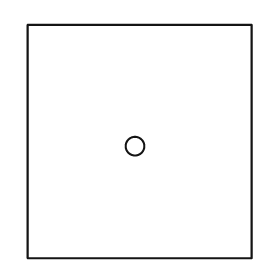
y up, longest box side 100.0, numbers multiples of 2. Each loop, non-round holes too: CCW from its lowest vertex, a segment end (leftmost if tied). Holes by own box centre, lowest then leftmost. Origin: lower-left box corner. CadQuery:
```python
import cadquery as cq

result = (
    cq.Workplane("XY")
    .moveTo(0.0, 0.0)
    .lineTo(96.0, 0.0)
    .lineTo(96.0, 100.0)
    .lineTo(0.0, 100.0)
    .close()
    .moveTo(46.0, 48.0)
    .circle(4.0)
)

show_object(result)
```